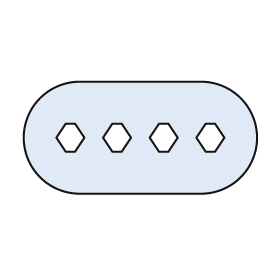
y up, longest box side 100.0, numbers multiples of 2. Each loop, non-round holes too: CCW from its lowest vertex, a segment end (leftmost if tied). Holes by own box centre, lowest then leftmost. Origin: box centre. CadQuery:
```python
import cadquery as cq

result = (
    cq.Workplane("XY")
    .moveTo(-26.0, -24.0)
    .lineTo(26.0, -24.0)
    .threePointArc((50.0, 0.0), (26.0, 24.0))
    .lineTo(-26.0, 24.0)
    .threePointArc((-50.0, 0.0), (-26.0, -24.0))
    .close()
    .moveTo(-32.0, -6.0)
    .lineTo(-28.0, -6.0)
    .lineTo(-24.0, 0.0)
    .lineTo(-28.0, 6.0)
    .lineTo(-32.0, 6.0)
    .lineTo(-36.0, 0.0)
    .close()
    .moveTo(-12.0, -6.0)
    .lineTo(-8.0, -6.0)
    .lineTo(-4.0, 0.0)
    .lineTo(-8.0, 6.0)
    .lineTo(-12.0, 6.0)
    .lineTo(-16.0, 0.0)
    .close()
    .moveTo(8.0, -6.0)
    .lineTo(12.0, -6.0)
    .lineTo(16.0, 0.0)
    .lineTo(12.0, 6.0)
    .lineTo(8.0, 6.0)
    .lineTo(4.0, 0.0)
    .close()
    .moveTo(28.0, -6.0)
    .lineTo(32.0, -6.0)
    .lineTo(36.0, 0.0)
    .lineTo(32.0, 6.0)
    .lineTo(28.0, 6.0)
    .lineTo(24.0, 0.0)
    .close()
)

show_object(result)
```